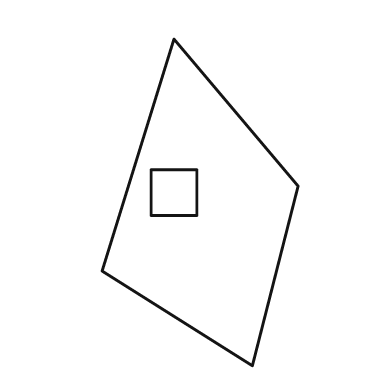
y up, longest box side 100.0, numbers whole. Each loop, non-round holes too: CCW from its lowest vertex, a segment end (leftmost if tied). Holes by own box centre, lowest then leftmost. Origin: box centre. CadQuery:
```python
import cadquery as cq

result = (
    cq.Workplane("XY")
    .moveTo(16.0, -50.0)
    .lineTo(30.0, 5.0)
    .lineTo(-8.0, 50.0)
    .lineTo(-30.0, -21.0)
    .close()
    .moveTo(-15.0, -4.0)
    .lineTo(-1.0, -4.0)
    .lineTo(-1.0, 10.0)
    .lineTo(-15.0, 10.0)
    .close()
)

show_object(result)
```